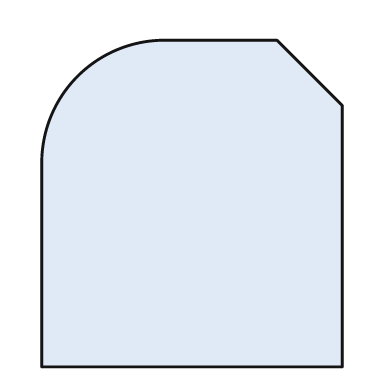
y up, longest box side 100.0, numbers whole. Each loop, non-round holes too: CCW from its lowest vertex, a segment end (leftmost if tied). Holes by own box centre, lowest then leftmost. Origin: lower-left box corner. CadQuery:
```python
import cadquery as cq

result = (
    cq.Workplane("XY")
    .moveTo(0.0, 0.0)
    .lineTo(92.0, 0.0)
    .lineTo(92.0, 80.0)
    .lineTo(72.0, 100.0)
    .lineTo(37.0, 100.0)
    .threePointArc((11.0, 89.0), (0.0, 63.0))
    .close()
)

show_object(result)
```